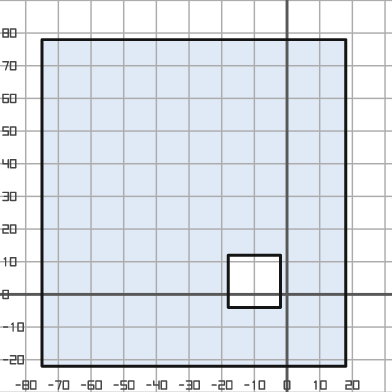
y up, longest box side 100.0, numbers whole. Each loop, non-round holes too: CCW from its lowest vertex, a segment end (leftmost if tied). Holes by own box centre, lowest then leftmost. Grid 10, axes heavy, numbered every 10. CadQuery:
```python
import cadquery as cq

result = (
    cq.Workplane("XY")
    .moveTo(-75.0, -22.0)
    .lineTo(18.0, -22.0)
    .lineTo(18.0, 78.0)
    .lineTo(-75.0, 78.0)
    .close()
    .moveTo(-18.0, -4.0)
    .lineTo(-2.0, -4.0)
    .lineTo(-2.0, 12.0)
    .lineTo(-18.0, 12.0)
    .close()
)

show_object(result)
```